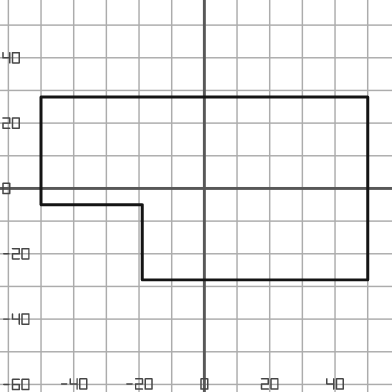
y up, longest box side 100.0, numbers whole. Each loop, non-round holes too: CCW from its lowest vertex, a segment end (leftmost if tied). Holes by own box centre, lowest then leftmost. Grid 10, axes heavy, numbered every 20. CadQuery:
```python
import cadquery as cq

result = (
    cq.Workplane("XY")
    .moveTo(-19.0, -28.0)
    .lineTo(50.0, -28.0)
    .lineTo(50.0, 28.0)
    .lineTo(-50.0, 28.0)
    .lineTo(-50.0, -5.0)
    .lineTo(-19.0, -5.0)
    .close()
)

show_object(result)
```